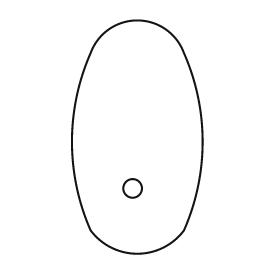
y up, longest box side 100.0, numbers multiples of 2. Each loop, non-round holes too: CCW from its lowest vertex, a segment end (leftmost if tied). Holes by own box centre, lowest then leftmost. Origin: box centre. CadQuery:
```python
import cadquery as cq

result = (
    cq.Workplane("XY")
    .moveTo(-20.0, -40.0)
    .threePointArc((0.0, -50.0), (20.0, -40.0))
    .threePointArc((28.0, -2.0), (20.0, 36.0))
    .threePointArc((0.0, 50.0), (-20.0, 36.0))
    .threePointArc((-28.0, -2.0), (-20.0, -40.0))
    .close()
    .moveTo(-2.0, -22.0)
    .circle(4.0)
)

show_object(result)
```